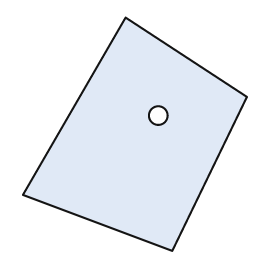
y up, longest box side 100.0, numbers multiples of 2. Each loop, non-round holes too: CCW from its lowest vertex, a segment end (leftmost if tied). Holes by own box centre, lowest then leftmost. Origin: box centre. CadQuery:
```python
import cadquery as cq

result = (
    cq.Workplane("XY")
    .moveTo(16.0, -50.0)
    .lineTo(48.0, 16.0)
    .lineTo(-4.0, 50.0)
    .lineTo(-48.0, -26.0)
    .close()
    .moveTo(10.0, 8.0)
    .circle(4.0)
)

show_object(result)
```